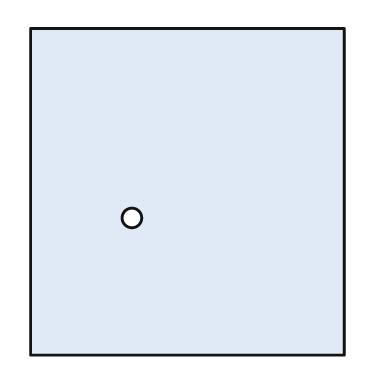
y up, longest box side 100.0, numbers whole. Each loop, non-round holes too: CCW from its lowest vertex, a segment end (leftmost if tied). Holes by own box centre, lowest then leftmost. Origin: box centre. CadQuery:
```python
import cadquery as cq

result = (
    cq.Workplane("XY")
    .moveTo(-48.0, -50.0)
    .lineTo(48.0, -50.0)
    .lineTo(48.0, 50.0)
    .lineTo(-48.0, 50.0)
    .close()
    .moveTo(-17.0, -8.0)
    .circle(3.0)
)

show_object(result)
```